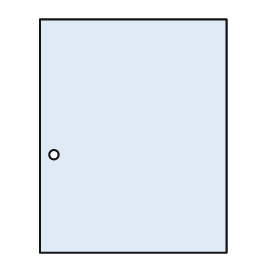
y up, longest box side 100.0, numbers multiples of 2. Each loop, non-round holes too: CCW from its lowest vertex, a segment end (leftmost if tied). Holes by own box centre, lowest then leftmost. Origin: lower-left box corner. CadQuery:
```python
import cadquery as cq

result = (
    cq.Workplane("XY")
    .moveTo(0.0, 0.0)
    .lineTo(80.0, 0.0)
    .lineTo(80.0, 100.0)
    .lineTo(0.0, 100.0)
    .close()
    .moveTo(6.0, 42.0)
    .circle(2.0)
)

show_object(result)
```